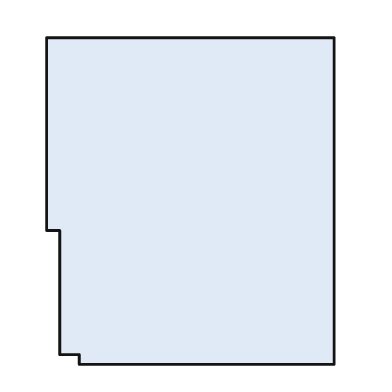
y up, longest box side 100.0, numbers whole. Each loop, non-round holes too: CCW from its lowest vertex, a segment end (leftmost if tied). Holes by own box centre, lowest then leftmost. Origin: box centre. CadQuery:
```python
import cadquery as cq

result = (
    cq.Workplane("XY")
    .moveTo(-34.0, -50.0)
    .lineTo(44.0, -50.0)
    .lineTo(44.0, 50.0)
    .lineTo(-44.0, 50.0)
    .lineTo(-44.0, -9.0)
    .lineTo(-40.0, -9.0)
    .lineTo(-40.0, -47.0)
    .lineTo(-34.0, -47.0)
    .close()
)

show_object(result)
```